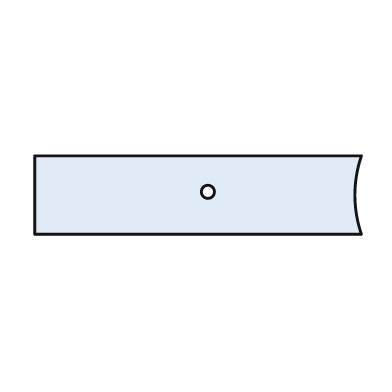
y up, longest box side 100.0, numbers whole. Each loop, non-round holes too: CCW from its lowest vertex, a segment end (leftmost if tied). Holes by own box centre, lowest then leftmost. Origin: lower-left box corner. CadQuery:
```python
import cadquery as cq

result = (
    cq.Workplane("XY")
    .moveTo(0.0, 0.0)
    .lineTo(100.0, 0.0)
    .threePointArc((98.0, 12.0), (100.0, 24.0))
    .lineTo(0.0, 24.0)
    .close()
    .moveTo(53.0, 13.0)
    .circle(2.0)
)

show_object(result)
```